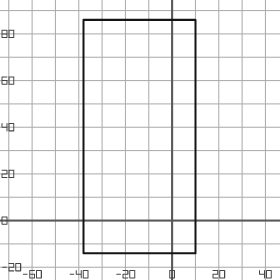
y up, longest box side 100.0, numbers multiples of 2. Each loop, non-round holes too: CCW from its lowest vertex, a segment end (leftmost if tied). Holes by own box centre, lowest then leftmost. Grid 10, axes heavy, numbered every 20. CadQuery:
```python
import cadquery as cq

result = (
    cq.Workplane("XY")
    .moveTo(-38.0, -14.0)
    .lineTo(10.0, -14.0)
    .lineTo(10.0, 86.0)
    .lineTo(-38.0, 86.0)
    .close()
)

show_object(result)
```